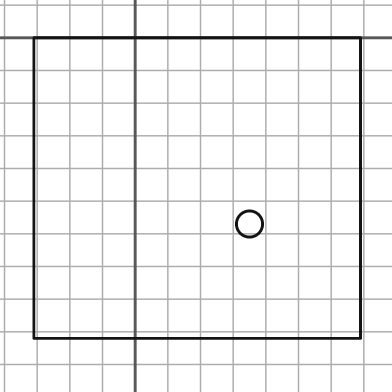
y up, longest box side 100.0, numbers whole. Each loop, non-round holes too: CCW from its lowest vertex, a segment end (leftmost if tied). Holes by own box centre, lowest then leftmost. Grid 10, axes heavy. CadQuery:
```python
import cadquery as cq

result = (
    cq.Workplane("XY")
    .moveTo(-31.0, -92.0)
    .lineTo(69.0, -92.0)
    .lineTo(69.0, 0.0)
    .lineTo(-31.0, 0.0)
    .close()
    .moveTo(35.0, -57.0)
    .circle(4.0)
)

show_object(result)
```